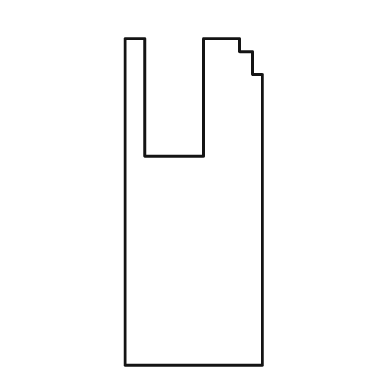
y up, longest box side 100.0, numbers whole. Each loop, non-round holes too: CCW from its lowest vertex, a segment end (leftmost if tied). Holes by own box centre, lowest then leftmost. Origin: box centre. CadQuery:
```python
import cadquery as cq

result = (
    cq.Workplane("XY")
    .moveTo(-21.0, -50.0)
    .lineTo(21.0, -50.0)
    .lineTo(21.0, 39.0)
    .lineTo(18.0, 39.0)
    .lineTo(18.0, 46.0)
    .lineTo(14.0, 46.0)
    .lineTo(14.0, 50.0)
    .lineTo(3.0, 50.0)
    .lineTo(3.0, 14.0)
    .lineTo(-15.0, 14.0)
    .lineTo(-15.0, 50.0)
    .lineTo(-21.0, 50.0)
    .close()
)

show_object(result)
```